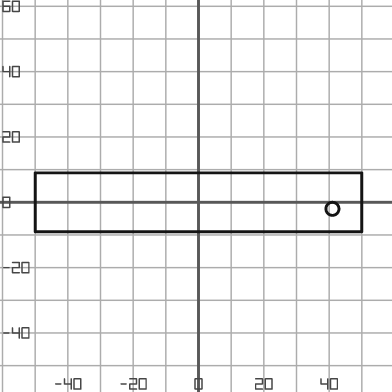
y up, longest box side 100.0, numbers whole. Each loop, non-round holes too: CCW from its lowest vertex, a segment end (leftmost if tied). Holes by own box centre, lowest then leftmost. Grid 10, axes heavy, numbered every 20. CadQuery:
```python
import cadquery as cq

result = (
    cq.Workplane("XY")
    .moveTo(-50.0, -9.0)
    .lineTo(50.0, -9.0)
    .lineTo(50.0, 9.0)
    .lineTo(-50.0, 9.0)
    .close()
    .moveTo(41.0, -2.0)
    .circle(2.0)
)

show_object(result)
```